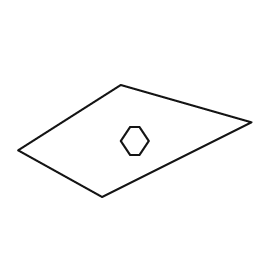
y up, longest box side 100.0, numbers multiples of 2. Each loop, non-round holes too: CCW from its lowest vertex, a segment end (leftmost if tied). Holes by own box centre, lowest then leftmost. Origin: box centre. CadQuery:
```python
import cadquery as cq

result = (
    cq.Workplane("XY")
    .moveTo(-14.0, -24.0)
    .lineTo(50.0, 8.0)
    .lineTo(-6.0, 24.0)
    .lineTo(-50.0, -4.0)
    .close()
    .moveTo(-2.0, -6.0)
    .lineTo(2.0, -6.0)
    .lineTo(6.0, 0.0)
    .lineTo(2.0, 6.0)
    .lineTo(-2.0, 6.0)
    .lineTo(-6.0, 0.0)
    .close()
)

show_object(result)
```